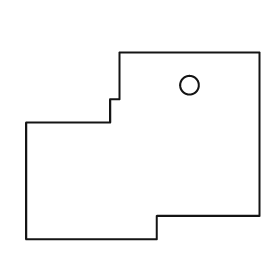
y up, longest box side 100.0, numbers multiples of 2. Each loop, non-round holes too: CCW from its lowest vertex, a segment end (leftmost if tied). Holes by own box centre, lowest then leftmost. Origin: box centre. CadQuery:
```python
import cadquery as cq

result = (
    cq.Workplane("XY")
    .moveTo(-50.0, -40.0)
    .lineTo(6.0, -40.0)
    .lineTo(6.0, -30.0)
    .lineTo(50.0, -30.0)
    .lineTo(50.0, 40.0)
    .lineTo(-10.0, 40.0)
    .lineTo(-10.0, 20.0)
    .lineTo(-14.0, 20.0)
    .lineTo(-14.0, 10.0)
    .lineTo(-50.0, 10.0)
    .close()
    .moveTo(20.0, 26.0)
    .circle(4.0)
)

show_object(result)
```